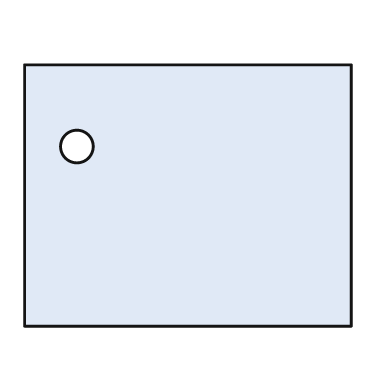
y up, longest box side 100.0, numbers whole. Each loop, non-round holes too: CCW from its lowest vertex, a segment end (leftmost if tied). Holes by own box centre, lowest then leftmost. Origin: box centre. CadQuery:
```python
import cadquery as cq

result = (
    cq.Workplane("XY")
    .moveTo(-50.0, -40.0)
    .lineTo(50.0, -40.0)
    .lineTo(50.0, 40.0)
    .lineTo(-50.0, 40.0)
    .close()
    .moveTo(-34.0, 15.0)
    .circle(5.0)
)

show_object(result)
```